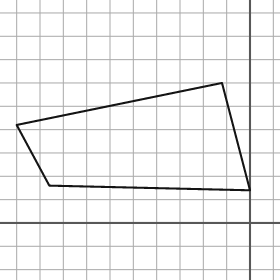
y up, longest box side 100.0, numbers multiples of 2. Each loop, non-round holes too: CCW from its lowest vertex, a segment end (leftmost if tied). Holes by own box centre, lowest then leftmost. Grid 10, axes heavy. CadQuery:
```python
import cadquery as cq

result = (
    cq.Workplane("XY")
    .moveTo(0.0, 14.0)
    .lineTo(-12.0, 60.0)
    .lineTo(-100.0, 42.0)
    .lineTo(-86.0, 16.0)
    .close()
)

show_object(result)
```